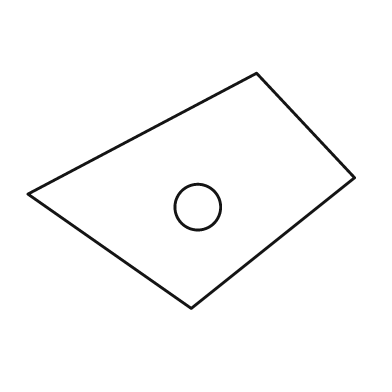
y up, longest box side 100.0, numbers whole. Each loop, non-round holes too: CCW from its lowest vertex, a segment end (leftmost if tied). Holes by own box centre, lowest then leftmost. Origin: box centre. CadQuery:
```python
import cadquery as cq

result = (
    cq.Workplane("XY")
    .moveTo(0.0, -36.0)
    .lineTo(50.0, 4.0)
    .lineTo(20.0, 36.0)
    .lineTo(-50.0, -1.0)
    .close()
    .moveTo(2.0, -5.0)
    .circle(7.0)
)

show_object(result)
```